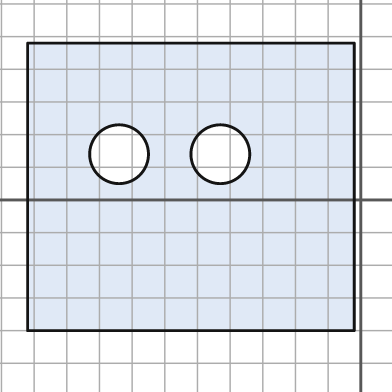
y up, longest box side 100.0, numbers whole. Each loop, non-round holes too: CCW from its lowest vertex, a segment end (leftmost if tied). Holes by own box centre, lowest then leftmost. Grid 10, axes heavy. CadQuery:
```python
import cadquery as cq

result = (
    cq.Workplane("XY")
    .moveTo(-102.0, -40.0)
    .lineTo(-2.0, -40.0)
    .lineTo(-2.0, 48.0)
    .lineTo(-102.0, 48.0)
    .close()
    .moveTo(-74.0, 14.0)
    .circle(9.0)
    .moveTo(-43.0, 14.0)
    .circle(9.0)
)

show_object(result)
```